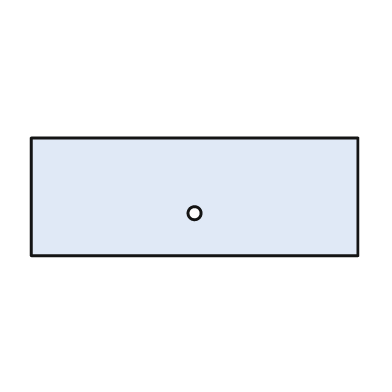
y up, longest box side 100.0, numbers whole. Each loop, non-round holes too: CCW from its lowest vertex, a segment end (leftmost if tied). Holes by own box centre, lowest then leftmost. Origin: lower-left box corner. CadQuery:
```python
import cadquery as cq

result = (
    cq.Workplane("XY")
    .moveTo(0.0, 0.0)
    .lineTo(100.0, 0.0)
    .lineTo(100.0, 36.0)
    .lineTo(0.0, 36.0)
    .close()
    .moveTo(50.0, 13.0)
    .circle(2.0)
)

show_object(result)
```